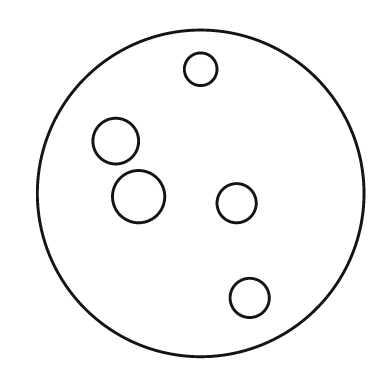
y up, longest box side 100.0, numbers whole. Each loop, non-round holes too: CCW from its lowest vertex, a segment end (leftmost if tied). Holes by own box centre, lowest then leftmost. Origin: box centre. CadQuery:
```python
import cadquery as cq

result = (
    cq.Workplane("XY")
    .moveTo(0.0, 0.0)
    .circle(50.0)
    .moveTo(15.0, -32.0)
    .circle(6.0)
    .moveTo(11.0, -3.0)
    .circle(6.0)
    .moveTo(-19.0, -1.0)
    .circle(8.0)
    .moveTo(-26.0, 16.0)
    .circle(7.0)
    .moveTo(0.0, 38.0)
    .circle(5.0)
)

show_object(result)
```